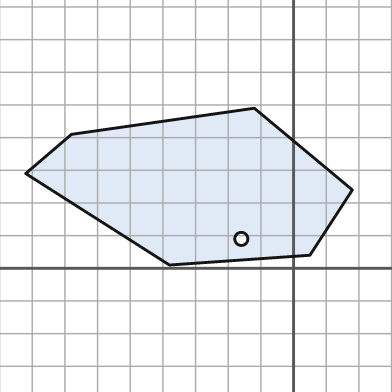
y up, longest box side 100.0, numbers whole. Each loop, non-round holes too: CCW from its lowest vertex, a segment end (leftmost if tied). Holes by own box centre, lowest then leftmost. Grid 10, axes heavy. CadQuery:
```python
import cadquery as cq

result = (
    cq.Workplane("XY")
    .moveTo(-38.0, 1.0)
    .lineTo(5.0, 4.0)
    .lineTo(18.0, 24.0)
    .lineTo(-12.0, 49.0)
    .lineTo(-68.0, 41.0)
    .lineTo(-82.0, 29.0)
    .close()
    .moveTo(-16.0, 9.0)
    .circle(2.0)
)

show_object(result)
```